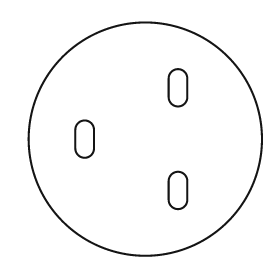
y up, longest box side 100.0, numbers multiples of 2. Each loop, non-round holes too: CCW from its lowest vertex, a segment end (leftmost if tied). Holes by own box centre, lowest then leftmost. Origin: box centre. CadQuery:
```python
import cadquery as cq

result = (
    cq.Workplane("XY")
    .moveTo(0.0, 0.0)
    .circle(50.0)
    .moveTo(10.0, -26.0)
    .threePointArc((14.0, -30.0), (18.0, -26.0))
    .lineTo(18.0, -18.0)
    .threePointArc((14.0, -14.0), (10.0, -18.0))
    .close()
    .moveTo(-30.0, -4.0)
    .threePointArc((-26.0, -8.0), (-22.0, -4.0))
    .lineTo(-22.0, 4.0)
    .threePointArc((-26.0, 8.0), (-30.0, 4.0))
    .close()
    .moveTo(10.0, 18.0)
    .threePointArc((14.0, 14.0), (18.0, 18.0))
    .lineTo(18.0, 26.0)
    .threePointArc((14.0, 30.0), (10.0, 26.0))
    .close()
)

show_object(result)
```